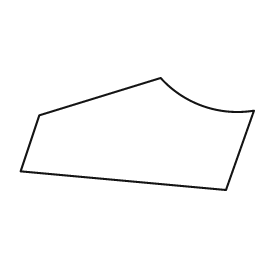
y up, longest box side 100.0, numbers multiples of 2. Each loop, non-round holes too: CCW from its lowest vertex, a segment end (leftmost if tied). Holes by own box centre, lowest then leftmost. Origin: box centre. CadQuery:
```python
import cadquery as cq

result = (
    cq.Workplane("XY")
    .moveTo(38.0, -24.0)
    .lineTo(50.0, 10.0)
    .threePointArc((28.0, 12.0), (10.0, 24.0))
    .lineTo(-42.0, 8.0)
    .lineTo(-50.0, -16.0)
    .close()
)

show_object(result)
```